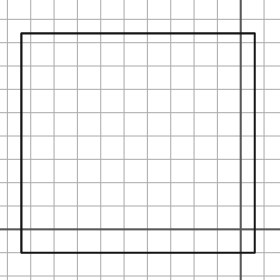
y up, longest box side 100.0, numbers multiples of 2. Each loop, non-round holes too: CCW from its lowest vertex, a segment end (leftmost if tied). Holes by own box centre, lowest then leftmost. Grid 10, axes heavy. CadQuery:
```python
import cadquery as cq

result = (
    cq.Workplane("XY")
    .moveTo(-94.0, -10.0)
    .lineTo(6.0, -10.0)
    .lineTo(6.0, 84.0)
    .lineTo(-94.0, 84.0)
    .close()
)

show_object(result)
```